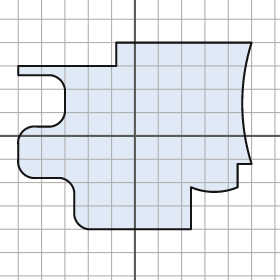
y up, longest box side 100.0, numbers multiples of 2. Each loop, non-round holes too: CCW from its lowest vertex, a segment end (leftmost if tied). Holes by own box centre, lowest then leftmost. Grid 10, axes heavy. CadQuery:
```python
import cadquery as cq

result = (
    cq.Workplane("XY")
    .moveTo(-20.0, -40.0)
    .lineTo(24.0, -40.0)
    .lineTo(24.0, -22.0)
    .threePointArc((34.0, -24.0), (44.0, -22.0))
    .lineTo(44.0, -12.0)
    .lineTo(50.0, -12.0)
    .threePointArc((46.0, 14.0), (50.0, 40.0))
    .lineTo(-8.0, 40.0)
    .lineTo(-8.0, 30.0)
    .lineTo(-50.0, 30.0)
    .lineTo(-50.0, 26.0)
    .lineTo(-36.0, 26.0)
    .threePointArc((-32.0, 24.0), (-30.0, 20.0))
    .lineTo(-30.0, 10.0)
    .threePointArc((-32.0, 6.0), (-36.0, 4.0))
    .lineTo(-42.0, 4.0)
    .threePointArc((-48.0, 2.0), (-50.0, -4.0))
    .lineTo(-50.0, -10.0)
    .threePointArc((-48.0, -16.0), (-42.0, -18.0))
    .lineTo(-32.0, -18.0)
    .threePointArc((-28.0, -20.0), (-26.0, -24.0))
    .lineTo(-26.0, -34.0)
    .threePointArc((-24.0, -38.0), (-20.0, -40.0))
    .close()
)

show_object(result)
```